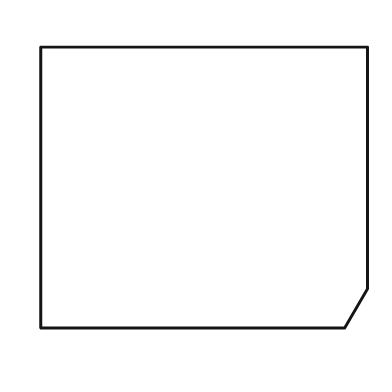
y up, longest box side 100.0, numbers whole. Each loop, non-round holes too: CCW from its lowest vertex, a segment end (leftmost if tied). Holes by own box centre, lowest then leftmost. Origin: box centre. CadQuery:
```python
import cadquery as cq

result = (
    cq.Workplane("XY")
    .moveTo(-50.0, -43.0)
    .lineTo(43.0, -43.0)
    .lineTo(50.0, -31.0)
    .lineTo(50.0, 43.0)
    .lineTo(-50.0, 43.0)
    .close()
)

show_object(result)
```